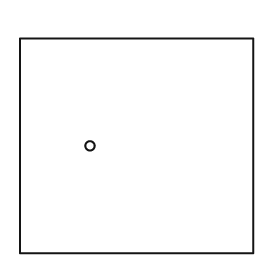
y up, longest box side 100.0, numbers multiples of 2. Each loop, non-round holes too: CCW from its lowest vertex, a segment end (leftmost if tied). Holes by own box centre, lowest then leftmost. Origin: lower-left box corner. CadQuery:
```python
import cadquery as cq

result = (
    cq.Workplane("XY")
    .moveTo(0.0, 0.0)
    .lineTo(100.0, 0.0)
    .lineTo(100.0, 92.0)
    .lineTo(0.0, 92.0)
    .close()
    .moveTo(30.0, 46.0)
    .circle(2.0)
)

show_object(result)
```